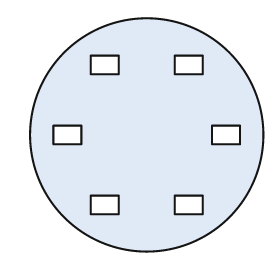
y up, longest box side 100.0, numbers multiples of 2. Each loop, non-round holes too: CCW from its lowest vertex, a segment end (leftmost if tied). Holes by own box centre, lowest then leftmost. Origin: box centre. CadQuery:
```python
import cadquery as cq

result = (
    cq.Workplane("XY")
    .moveTo(0.0, 0.0)
    .circle(50.0)
    .moveTo(-24.0, -34.0)
    .lineTo(-12.0, -34.0)
    .lineTo(-12.0, -26.0)
    .lineTo(-24.0, -26.0)
    .close()
    .moveTo(12.0, -34.0)
    .lineTo(24.0, -34.0)
    .lineTo(24.0, -26.0)
    .lineTo(12.0, -26.0)
    .close()
    .moveTo(-40.0, -4.0)
    .lineTo(-28.0, -4.0)
    .lineTo(-28.0, 4.0)
    .lineTo(-40.0, 4.0)
    .close()
    .moveTo(28.0, -4.0)
    .lineTo(40.0, -4.0)
    .lineTo(40.0, 4.0)
    .lineTo(28.0, 4.0)
    .close()
    .moveTo(-24.0, 26.0)
    .lineTo(-12.0, 26.0)
    .lineTo(-12.0, 34.0)
    .lineTo(-24.0, 34.0)
    .close()
    .moveTo(12.0, 26.0)
    .lineTo(24.0, 26.0)
    .lineTo(24.0, 34.0)
    .lineTo(12.0, 34.0)
    .close()
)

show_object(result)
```